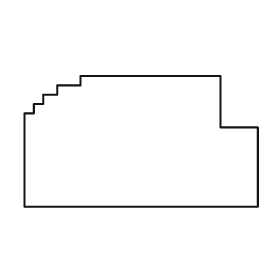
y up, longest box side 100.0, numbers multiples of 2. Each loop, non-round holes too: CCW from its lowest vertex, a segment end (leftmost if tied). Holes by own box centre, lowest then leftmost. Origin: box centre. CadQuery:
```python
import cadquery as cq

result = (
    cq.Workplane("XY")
    .moveTo(-50.0, -28.0)
    .lineTo(50.0, -28.0)
    .lineTo(50.0, 6.0)
    .lineTo(34.0, 6.0)
    .lineTo(34.0, 28.0)
    .lineTo(-26.0, 28.0)
    .lineTo(-26.0, 24.0)
    .lineTo(-36.0, 24.0)
    .lineTo(-36.0, 20.0)
    .lineTo(-42.0, 20.0)
    .lineTo(-42.0, 16.0)
    .lineTo(-46.0, 16.0)
    .lineTo(-46.0, 12.0)
    .lineTo(-50.0, 12.0)
    .close()
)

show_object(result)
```